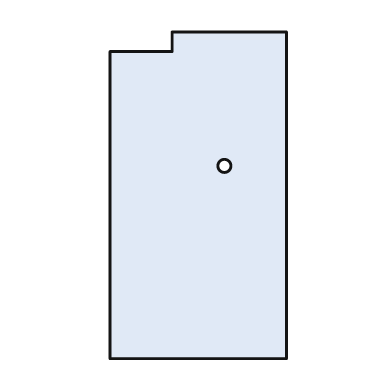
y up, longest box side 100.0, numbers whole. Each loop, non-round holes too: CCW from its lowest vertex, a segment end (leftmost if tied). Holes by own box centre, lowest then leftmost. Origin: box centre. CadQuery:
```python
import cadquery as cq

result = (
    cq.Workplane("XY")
    .moveTo(-27.0, -50.0)
    .lineTo(27.0, -50.0)
    .lineTo(27.0, 50.0)
    .lineTo(-8.0, 50.0)
    .lineTo(-8.0, 44.0)
    .lineTo(-27.0, 44.0)
    .close()
    .moveTo(8.0, 9.0)
    .circle(2.0)
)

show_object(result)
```